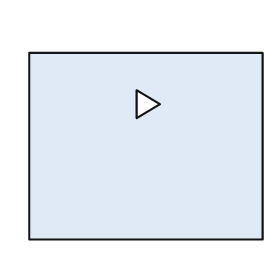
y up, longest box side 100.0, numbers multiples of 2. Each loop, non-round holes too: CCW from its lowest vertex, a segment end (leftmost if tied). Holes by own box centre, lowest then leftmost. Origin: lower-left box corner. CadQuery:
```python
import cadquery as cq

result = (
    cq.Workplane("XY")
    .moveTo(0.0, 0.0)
    .lineTo(100.0, 0.0)
    .lineTo(100.0, 80.0)
    .lineTo(0.0, 80.0)
    .close()
    .moveTo(46.0, 52.0)
    .lineTo(56.0, 58.0)
    .lineTo(46.0, 64.0)
    .close()
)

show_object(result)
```